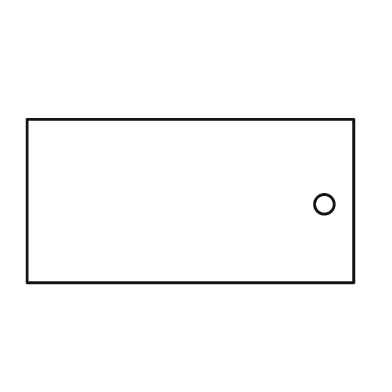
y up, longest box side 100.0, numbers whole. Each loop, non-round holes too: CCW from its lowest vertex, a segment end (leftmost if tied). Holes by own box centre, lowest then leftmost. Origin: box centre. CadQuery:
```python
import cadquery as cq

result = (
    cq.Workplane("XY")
    .moveTo(-50.0, -25.0)
    .lineTo(50.0, -25.0)
    .lineTo(50.0, 25.0)
    .lineTo(-50.0, 25.0)
    .close()
    .moveTo(41.0, -1.0)
    .circle(3.0)
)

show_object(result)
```